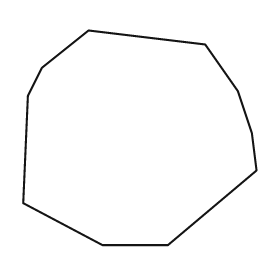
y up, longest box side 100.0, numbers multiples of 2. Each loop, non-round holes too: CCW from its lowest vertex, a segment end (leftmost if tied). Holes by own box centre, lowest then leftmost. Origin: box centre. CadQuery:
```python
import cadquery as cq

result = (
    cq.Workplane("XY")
    .moveTo(-16.0, -46.0)
    .lineTo(12.0, -46.0)
    .lineTo(50.0, -14.0)
    .lineTo(48.0, 2.0)
    .lineTo(42.0, 20.0)
    .lineTo(28.0, 40.0)
    .lineTo(-22.0, 46.0)
    .lineTo(-42.0, 30.0)
    .lineTo(-48.0, 18.0)
    .lineTo(-50.0, -28.0)
    .close()
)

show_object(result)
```